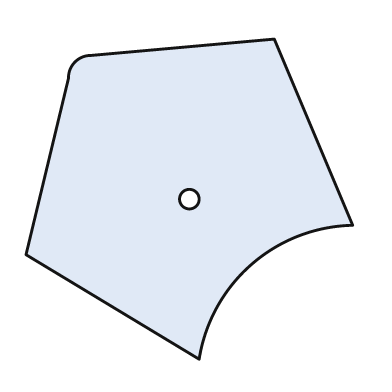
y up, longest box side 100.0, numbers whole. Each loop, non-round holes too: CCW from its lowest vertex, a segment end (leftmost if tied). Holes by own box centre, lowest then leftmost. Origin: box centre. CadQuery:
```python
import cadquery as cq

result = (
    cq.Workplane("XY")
    .moveTo(3.0, -49.0)
    .threePointArc((19.0, -20.0), (50.0, -8.0))
    .lineTo(26.0, 49.0)
    .lineTo(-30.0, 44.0)
    .threePointArc((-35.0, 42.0), (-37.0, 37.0))
    .lineTo(-50.0, -17.0)
    .close()
    .moveTo(0.0, 0.0)
    .circle(3.0)
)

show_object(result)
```